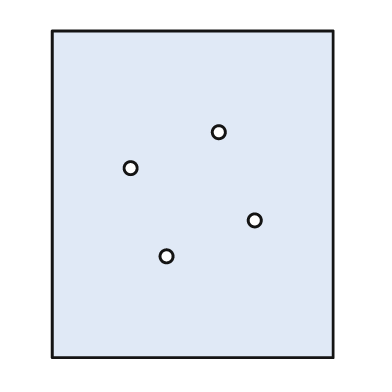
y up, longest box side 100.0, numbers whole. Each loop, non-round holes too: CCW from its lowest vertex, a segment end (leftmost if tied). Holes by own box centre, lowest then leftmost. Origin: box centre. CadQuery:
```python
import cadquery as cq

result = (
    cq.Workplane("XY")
    .moveTo(-43.0, -50.0)
    .lineTo(43.0, -50.0)
    .lineTo(43.0, 50.0)
    .lineTo(-43.0, 50.0)
    .close()
    .moveTo(-8.0, -19.0)
    .circle(2.0)
    .moveTo(19.0, -8.0)
    .circle(2.0)
    .moveTo(-19.0, 8.0)
    .circle(2.0)
    .moveTo(8.0, 19.0)
    .circle(2.0)
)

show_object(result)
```